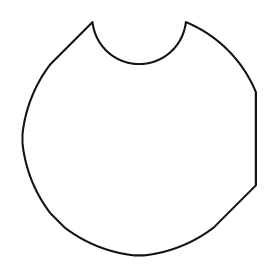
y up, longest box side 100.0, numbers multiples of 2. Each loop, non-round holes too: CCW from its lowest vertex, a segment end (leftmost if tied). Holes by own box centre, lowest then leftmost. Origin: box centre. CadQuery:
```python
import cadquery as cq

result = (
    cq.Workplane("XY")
    .moveTo(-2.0, -50.0)
    .lineTo(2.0, -50.0)
    .threePointArc((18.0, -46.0), (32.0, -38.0))
    .lineTo(50.0, -20.0)
    .lineTo(50.0, 20.0)
    .threePointArc((38.0, 38.0), (20.0, 50.0))
    .threePointArc((0.0, 32.0), (-20.0, 50.0))
    .lineTo(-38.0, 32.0)
    .threePointArc((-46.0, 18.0), (-50.0, 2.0))
    .lineTo(-50.0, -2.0)
    .threePointArc((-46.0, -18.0), (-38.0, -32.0))
    .lineTo(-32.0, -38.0)
    .threePointArc((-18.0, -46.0), (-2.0, -50.0))
    .close()
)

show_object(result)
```